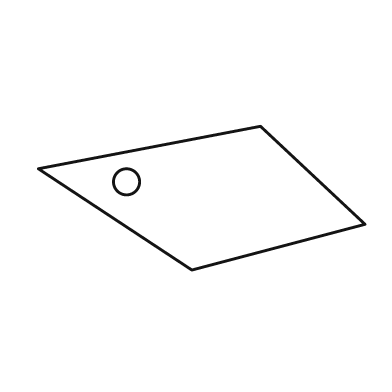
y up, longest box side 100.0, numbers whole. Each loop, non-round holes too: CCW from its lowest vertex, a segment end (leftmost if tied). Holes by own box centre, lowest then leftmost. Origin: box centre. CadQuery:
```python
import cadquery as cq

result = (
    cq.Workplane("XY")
    .moveTo(-3.0, -22.0)
    .lineTo(50.0, -8.0)
    .lineTo(18.0, 22.0)
    .lineTo(-50.0, 9.0)
    .close()
    .moveTo(-23.0, 5.0)
    .circle(4.0)
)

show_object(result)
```